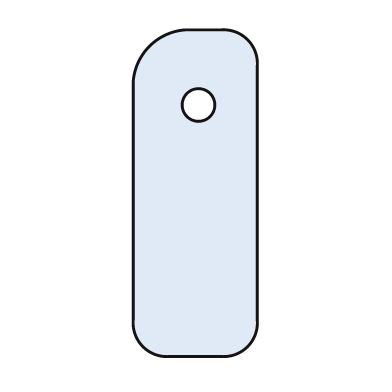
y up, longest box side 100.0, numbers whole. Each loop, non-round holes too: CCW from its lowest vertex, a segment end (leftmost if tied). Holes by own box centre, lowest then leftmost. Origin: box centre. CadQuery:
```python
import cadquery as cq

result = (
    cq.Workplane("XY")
    .moveTo(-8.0, -50.0)
    .lineTo(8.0, -50.0)
    .threePointArc((16.0, -47.0), (19.0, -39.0))
    .lineTo(19.0, 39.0)
    .threePointArc((16.0, 47.0), (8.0, 50.0))
    .lineTo(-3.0, 50.0)
    .threePointArc((-14.0, 45.0), (-19.0, 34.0))
    .lineTo(-19.0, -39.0)
    .threePointArc((-16.0, -47.0), (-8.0, -50.0))
    .close()
    .moveTo(1.0, 27.0)
    .circle(5.0)
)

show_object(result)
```